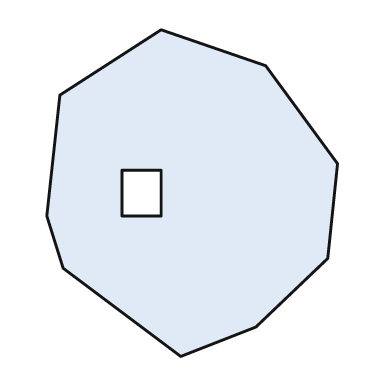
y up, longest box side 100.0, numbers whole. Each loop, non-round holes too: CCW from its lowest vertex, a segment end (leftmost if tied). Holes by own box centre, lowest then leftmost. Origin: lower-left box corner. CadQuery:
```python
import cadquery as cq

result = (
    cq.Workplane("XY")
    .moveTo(41.0, 0.0)
    .lineTo(64.0, 9.0)
    .lineTo(86.0, 30.0)
    .lineTo(89.0, 59.0)
    .lineTo(67.0, 89.0)
    .lineTo(35.0, 100.0)
    .lineTo(4.0, 80.0)
    .lineTo(0.0, 43.0)
    .lineTo(5.0, 27.0)
    .close()
    .moveTo(23.0, 43.0)
    .lineTo(35.0, 43.0)
    .lineTo(35.0, 57.0)
    .lineTo(23.0, 57.0)
    .close()
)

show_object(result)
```